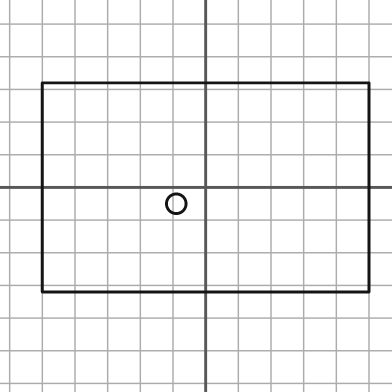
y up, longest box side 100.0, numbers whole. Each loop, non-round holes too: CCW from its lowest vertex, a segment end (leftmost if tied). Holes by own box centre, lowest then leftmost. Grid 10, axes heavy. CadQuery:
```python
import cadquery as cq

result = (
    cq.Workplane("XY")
    .moveTo(-50.0, -32.0)
    .lineTo(50.0, -32.0)
    .lineTo(50.0, 32.0)
    .lineTo(-50.0, 32.0)
    .close()
    .moveTo(-9.0, -5.0)
    .circle(3.0)
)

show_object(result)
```